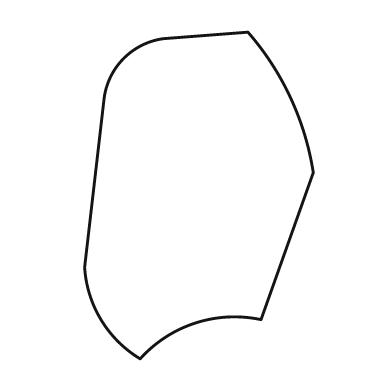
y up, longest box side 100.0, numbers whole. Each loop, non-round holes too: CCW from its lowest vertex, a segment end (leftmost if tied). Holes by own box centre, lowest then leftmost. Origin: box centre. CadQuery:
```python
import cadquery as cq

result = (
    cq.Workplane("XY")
    .moveTo(-18.0, -50.0)
    .threePointArc((-1.0, -39.0), (19.0, -38.0))
    .lineTo(35.0, 7.0)
    .threePointArc((28.0, 30.0), (15.0, 50.0))
    .lineTo(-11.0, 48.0)
    .threePointArc((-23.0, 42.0), (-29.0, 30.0))
    .lineTo(-35.0, -22.0)
    .threePointArc((-30.0, -38.0), (-18.0, -50.0))
    .close()
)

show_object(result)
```